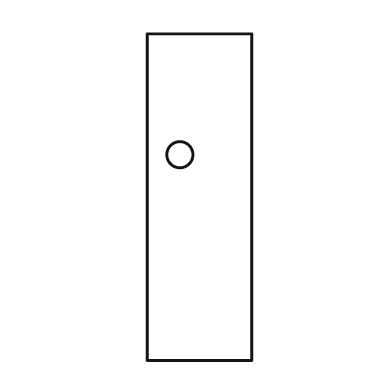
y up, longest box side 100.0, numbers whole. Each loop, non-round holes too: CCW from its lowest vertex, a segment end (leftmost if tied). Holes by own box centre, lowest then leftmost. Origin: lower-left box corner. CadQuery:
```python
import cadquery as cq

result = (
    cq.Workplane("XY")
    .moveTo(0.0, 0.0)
    .lineTo(32.0, 0.0)
    .lineTo(32.0, 100.0)
    .lineTo(0.0, 100.0)
    .close()
    .moveTo(10.0, 63.0)
    .circle(4.0)
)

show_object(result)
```